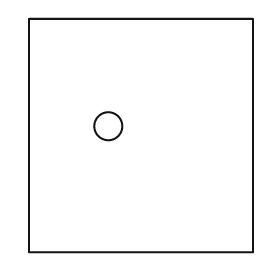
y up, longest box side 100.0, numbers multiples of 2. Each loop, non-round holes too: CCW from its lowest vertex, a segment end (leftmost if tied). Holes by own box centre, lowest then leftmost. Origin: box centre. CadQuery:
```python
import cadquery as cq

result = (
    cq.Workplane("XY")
    .moveTo(-48.0, -50.0)
    .lineTo(48.0, -50.0)
    .lineTo(48.0, 50.0)
    .lineTo(-48.0, 50.0)
    .close()
    .moveTo(-14.0, 4.0)
    .circle(6.0)
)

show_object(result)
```